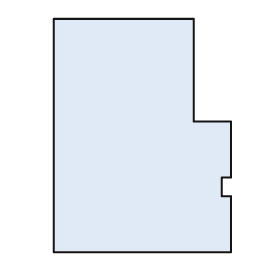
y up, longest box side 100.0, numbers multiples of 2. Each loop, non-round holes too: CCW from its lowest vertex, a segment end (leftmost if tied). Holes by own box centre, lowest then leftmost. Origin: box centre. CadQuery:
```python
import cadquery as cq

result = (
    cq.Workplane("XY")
    .moveTo(-38.0, -50.0)
    .lineTo(38.0, -50.0)
    .lineTo(38.0, -26.0)
    .lineTo(34.0, -26.0)
    .lineTo(34.0, -18.0)
    .lineTo(38.0, -18.0)
    .lineTo(38.0, 6.0)
    .lineTo(22.0, 6.0)
    .lineTo(22.0, 50.0)
    .lineTo(-38.0, 50.0)
    .close()
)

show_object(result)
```